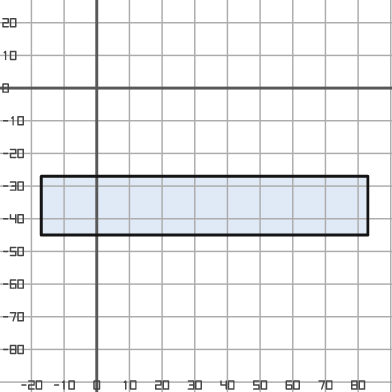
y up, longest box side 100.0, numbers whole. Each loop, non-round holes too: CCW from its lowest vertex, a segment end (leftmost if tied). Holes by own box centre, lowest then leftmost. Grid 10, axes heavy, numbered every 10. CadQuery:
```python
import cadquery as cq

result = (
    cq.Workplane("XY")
    .moveTo(-17.0, -45.0)
    .lineTo(83.0, -45.0)
    .lineTo(83.0, -27.0)
    .lineTo(-17.0, -27.0)
    .close()
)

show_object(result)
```